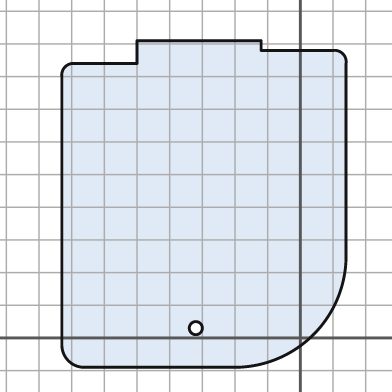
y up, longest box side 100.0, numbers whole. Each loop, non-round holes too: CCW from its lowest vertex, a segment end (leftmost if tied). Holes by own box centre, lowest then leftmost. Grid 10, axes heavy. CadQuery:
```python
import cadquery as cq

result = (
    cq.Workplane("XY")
    .moveTo(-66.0, -9.0)
    .lineTo(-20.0, -9.0)
    .threePointArc((4.0, 1.0), (14.0, 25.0))
    .lineTo(14.0, 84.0)
    .threePointArc((13.0, 87.0), (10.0, 88.0))
    .lineTo(-12.0, 88.0)
    .lineTo(-12.0, 91.0)
    .lineTo(-50.0, 91.0)
    .lineTo(-50.0, 84.0)
    .lineTo(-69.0, 84.0)
    .threePointArc((-72.0, 83.0), (-73.0, 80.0))
    .lineTo(-73.0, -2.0)
    .threePointArc((-71.0, -7.0), (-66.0, -9.0))
    .close()
    .moveTo(-32.0, 3.0)
    .circle(2.0)
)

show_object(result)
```